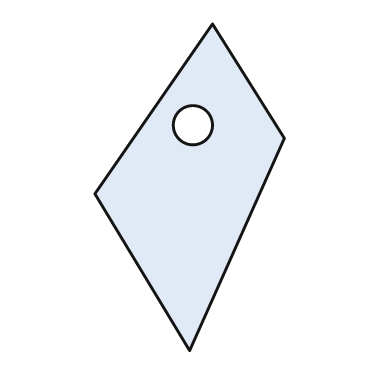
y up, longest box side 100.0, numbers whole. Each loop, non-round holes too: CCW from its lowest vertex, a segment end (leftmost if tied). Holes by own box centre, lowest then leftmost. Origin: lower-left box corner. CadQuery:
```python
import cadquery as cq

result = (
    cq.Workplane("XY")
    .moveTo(29.0, 0.0)
    .lineTo(58.0, 65.0)
    .lineTo(36.0, 100.0)
    .lineTo(0.0, 48.0)
    .close()
    .moveTo(30.0, 69.0)
    .circle(6.0)
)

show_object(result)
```